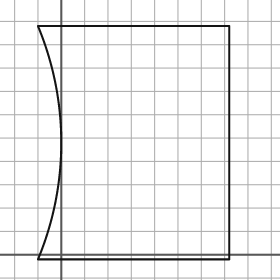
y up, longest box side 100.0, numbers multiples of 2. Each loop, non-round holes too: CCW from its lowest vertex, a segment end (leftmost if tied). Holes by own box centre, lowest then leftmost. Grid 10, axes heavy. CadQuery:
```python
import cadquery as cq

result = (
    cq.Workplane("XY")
    .moveTo(-10.0, -2.0)
    .lineTo(72.0, -2.0)
    .lineTo(72.0, 98.0)
    .lineTo(-10.0, 98.0)
    .threePointArc((0.0, 48.0), (-10.0, -2.0))
    .close()
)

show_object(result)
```